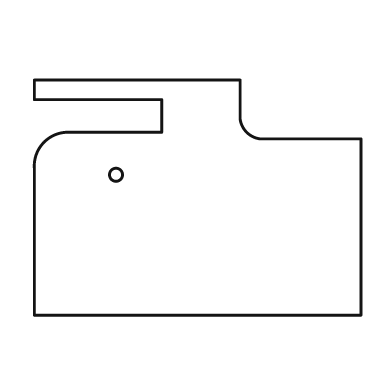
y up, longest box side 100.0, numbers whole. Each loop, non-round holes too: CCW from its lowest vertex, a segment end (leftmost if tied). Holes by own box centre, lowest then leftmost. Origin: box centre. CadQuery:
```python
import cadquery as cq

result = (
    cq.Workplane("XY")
    .moveTo(-50.0, -36.0)
    .lineTo(50.0, -36.0)
    .lineTo(50.0, 18.0)
    .lineTo(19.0, 18.0)
    .threePointArc((15.0, 20.0), (13.0, 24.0))
    .lineTo(13.0, 36.0)
    .lineTo(-50.0, 36.0)
    .lineTo(-50.0, 30.0)
    .lineTo(-11.0, 30.0)
    .lineTo(-11.0, 20.0)
    .lineTo(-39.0, 20.0)
    .threePointArc((-47.0, 17.0), (-50.0, 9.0))
    .close()
    .moveTo(-25.0, 7.0)
    .circle(2.0)
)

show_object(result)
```